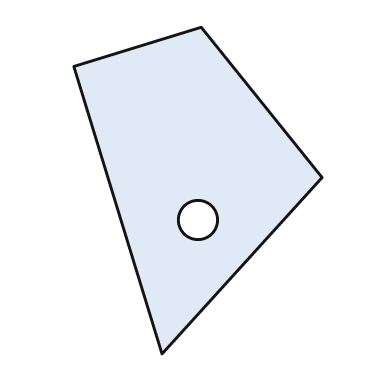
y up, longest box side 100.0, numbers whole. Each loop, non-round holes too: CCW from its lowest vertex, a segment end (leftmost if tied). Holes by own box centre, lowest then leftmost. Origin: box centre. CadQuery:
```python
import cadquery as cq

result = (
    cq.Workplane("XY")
    .moveTo(-11.0, -50.0)
    .lineTo(38.0, 4.0)
    .lineTo(1.0, 50.0)
    .lineTo(-38.0, 38.0)
    .close()
    .moveTo(0.0, -9.0)
    .circle(6.0)
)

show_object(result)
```